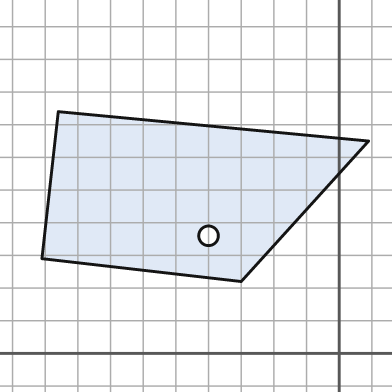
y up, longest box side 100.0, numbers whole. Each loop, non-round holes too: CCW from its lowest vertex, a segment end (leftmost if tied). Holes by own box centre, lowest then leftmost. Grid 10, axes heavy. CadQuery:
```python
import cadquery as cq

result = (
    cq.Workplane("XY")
    .moveTo(-30.0, 22.0)
    .lineTo(9.0, 65.0)
    .lineTo(-86.0, 74.0)
    .lineTo(-91.0, 29.0)
    .close()
    .moveTo(-40.0, 36.0)
    .circle(3.0)
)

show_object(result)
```